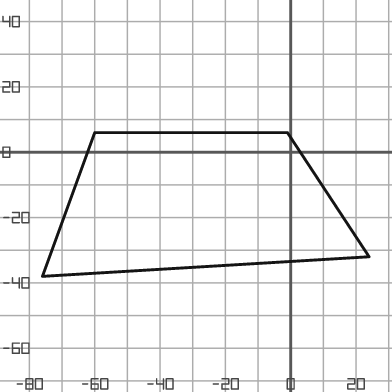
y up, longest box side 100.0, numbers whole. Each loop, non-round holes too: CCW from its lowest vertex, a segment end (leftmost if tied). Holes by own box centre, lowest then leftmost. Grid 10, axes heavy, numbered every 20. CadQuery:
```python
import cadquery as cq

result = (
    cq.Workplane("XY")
    .moveTo(-76.0, -38.0)
    .lineTo(24.0, -32.0)
    .lineTo(-1.0, 6.0)
    .lineTo(-60.0, 6.0)
    .close()
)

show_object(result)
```